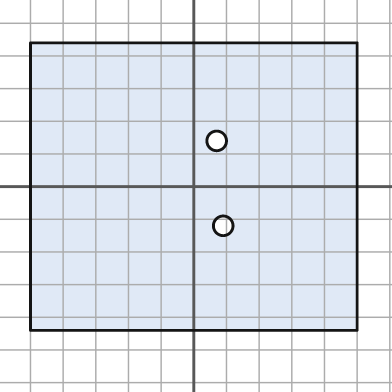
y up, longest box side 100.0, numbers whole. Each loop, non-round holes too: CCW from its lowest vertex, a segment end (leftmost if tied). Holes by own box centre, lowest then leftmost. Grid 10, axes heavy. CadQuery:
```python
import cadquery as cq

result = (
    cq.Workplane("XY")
    .moveTo(-50.0, -44.0)
    .lineTo(50.0, -44.0)
    .lineTo(50.0, 44.0)
    .lineTo(-50.0, 44.0)
    .close()
    .moveTo(9.0, -12.0)
    .circle(3.0)
    .moveTo(7.0, 14.0)
    .circle(3.0)
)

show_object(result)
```